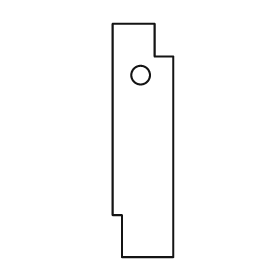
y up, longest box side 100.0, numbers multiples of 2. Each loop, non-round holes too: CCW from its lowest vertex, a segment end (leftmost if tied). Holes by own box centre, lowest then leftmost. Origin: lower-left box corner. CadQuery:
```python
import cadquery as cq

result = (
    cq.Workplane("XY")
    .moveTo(4.0, 0.0)
    .lineTo(26.0, 0.0)
    .lineTo(26.0, 86.0)
    .lineTo(18.0, 86.0)
    .lineTo(18.0, 100.0)
    .lineTo(0.0, 100.0)
    .lineTo(0.0, 18.0)
    .lineTo(4.0, 18.0)
    .close()
    .moveTo(12.0, 78.0)
    .circle(4.0)
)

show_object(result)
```